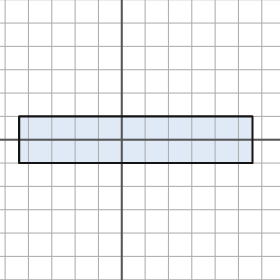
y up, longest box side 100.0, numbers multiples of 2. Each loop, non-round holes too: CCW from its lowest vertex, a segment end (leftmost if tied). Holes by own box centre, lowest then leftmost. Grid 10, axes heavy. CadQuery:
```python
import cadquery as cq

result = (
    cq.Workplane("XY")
    .moveTo(-44.0, -10.0)
    .lineTo(56.0, -10.0)
    .lineTo(56.0, 10.0)
    .lineTo(-44.0, 10.0)
    .close()
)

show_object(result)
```